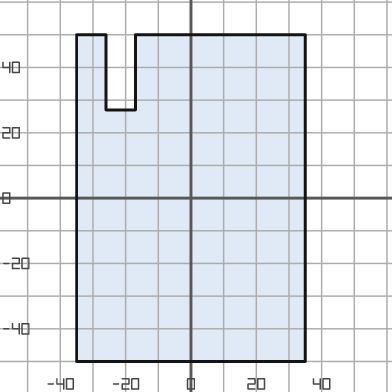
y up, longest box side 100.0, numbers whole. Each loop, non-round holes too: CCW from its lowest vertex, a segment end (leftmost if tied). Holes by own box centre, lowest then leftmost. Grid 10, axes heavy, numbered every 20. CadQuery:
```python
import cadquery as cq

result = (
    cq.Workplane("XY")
    .moveTo(-35.0, -50.0)
    .lineTo(35.0, -50.0)
    .lineTo(35.0, 50.0)
    .lineTo(-17.0, 50.0)
    .lineTo(-17.0, 27.0)
    .lineTo(-26.0, 27.0)
    .lineTo(-26.0, 50.0)
    .lineTo(-35.0, 50.0)
    .close()
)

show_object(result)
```